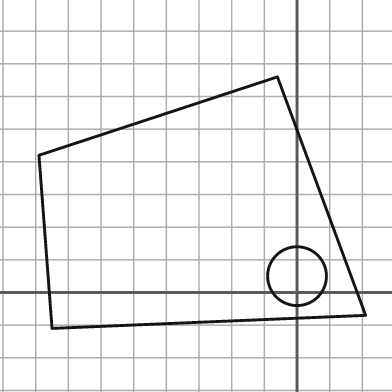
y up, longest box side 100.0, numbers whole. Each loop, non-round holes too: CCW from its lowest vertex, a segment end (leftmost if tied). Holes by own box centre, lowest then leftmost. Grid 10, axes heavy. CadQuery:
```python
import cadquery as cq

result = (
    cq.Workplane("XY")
    .moveTo(-75.0, -11.0)
    .lineTo(21.0, -7.0)
    .lineTo(-6.0, 66.0)
    .lineTo(-79.0, 42.0)
    .close()
    .moveTo(0.0, 5.0)
    .circle(9.0)
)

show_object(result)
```